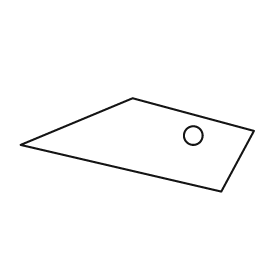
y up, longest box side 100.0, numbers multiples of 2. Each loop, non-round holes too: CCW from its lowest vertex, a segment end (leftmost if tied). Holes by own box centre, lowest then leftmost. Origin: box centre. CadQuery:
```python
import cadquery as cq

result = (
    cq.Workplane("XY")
    .moveTo(36.0, -20.0)
    .lineTo(50.0, 6.0)
    .lineTo(-2.0, 20.0)
    .lineTo(-50.0, 0.0)
    .close()
    .moveTo(24.0, 4.0)
    .circle(4.0)
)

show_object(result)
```